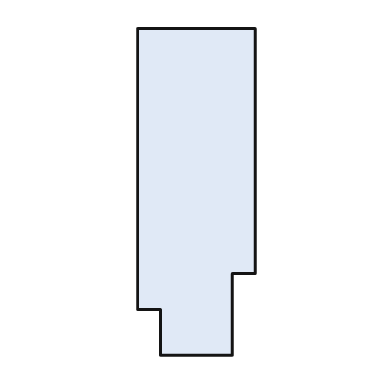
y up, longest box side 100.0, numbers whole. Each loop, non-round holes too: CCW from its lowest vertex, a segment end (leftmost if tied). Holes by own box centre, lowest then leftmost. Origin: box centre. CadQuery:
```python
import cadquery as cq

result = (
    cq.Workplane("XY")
    .moveTo(-11.0, -50.0)
    .lineTo(11.0, -50.0)
    .lineTo(11.0, -25.0)
    .lineTo(18.0, -25.0)
    .lineTo(18.0, 50.0)
    .lineTo(-18.0, 50.0)
    .lineTo(-18.0, -36.0)
    .lineTo(-11.0, -36.0)
    .close()
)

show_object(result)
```